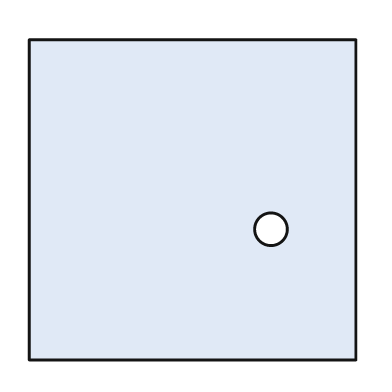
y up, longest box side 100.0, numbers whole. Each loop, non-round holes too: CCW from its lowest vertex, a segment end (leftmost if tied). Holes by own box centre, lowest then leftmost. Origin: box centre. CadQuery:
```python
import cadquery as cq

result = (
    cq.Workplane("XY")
    .moveTo(-50.0, -49.0)
    .lineTo(50.0, -49.0)
    .lineTo(50.0, 49.0)
    .lineTo(-50.0, 49.0)
    .close()
    .moveTo(24.0, -9.0)
    .circle(5.0)
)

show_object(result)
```